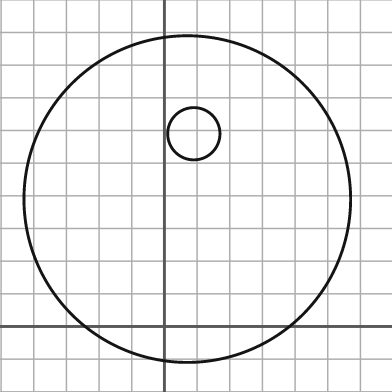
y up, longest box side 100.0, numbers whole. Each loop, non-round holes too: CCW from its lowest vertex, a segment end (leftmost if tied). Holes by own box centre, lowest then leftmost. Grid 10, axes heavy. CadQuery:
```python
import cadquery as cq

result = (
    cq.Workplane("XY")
    .moveTo(7.0, 39.0)
    .circle(50.0)
    .moveTo(9.0, 59.0)
    .circle(8.0)
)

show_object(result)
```